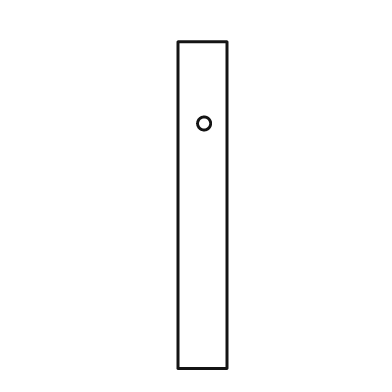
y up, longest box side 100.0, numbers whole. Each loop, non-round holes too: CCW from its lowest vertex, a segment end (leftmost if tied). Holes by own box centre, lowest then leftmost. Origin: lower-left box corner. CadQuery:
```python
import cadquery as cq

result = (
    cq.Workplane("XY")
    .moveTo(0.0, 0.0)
    .lineTo(15.0, 0.0)
    .lineTo(15.0, 100.0)
    .lineTo(0.0, 100.0)
    .close()
    .moveTo(8.0, 75.0)
    .circle(2.0)
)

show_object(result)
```